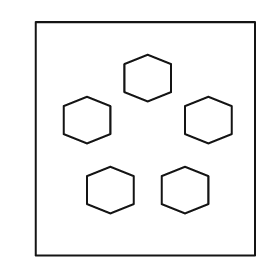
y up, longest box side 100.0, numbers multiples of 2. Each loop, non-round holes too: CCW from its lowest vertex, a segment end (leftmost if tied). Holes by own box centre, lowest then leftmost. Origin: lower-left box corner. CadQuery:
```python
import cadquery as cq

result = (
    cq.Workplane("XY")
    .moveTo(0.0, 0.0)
    .lineTo(94.0, 0.0)
    .lineTo(94.0, 100.0)
    .lineTo(0.0, 100.0)
    .close()
    .moveTo(32.0, 18.0)
    .lineTo(42.0, 22.0)
    .lineTo(42.0, 34.0)
    .lineTo(32.0, 38.0)
    .lineTo(22.0, 34.0)
    .lineTo(22.0, 22.0)
    .close()
    .moveTo(64.0, 18.0)
    .lineTo(74.0, 22.0)
    .lineTo(74.0, 34.0)
    .lineTo(64.0, 38.0)
    .lineTo(54.0, 34.0)
    .lineTo(54.0, 22.0)
    .close()
    .moveTo(22.0, 48.0)
    .lineTo(32.0, 52.0)
    .lineTo(32.0, 64.0)
    .lineTo(22.0, 68.0)
    .lineTo(12.0, 64.0)
    .lineTo(12.0, 52.0)
    .close()
    .moveTo(74.0, 48.0)
    .lineTo(84.0, 52.0)
    .lineTo(84.0, 64.0)
    .lineTo(74.0, 68.0)
    .lineTo(64.0, 64.0)
    .lineTo(64.0, 52.0)
    .close()
    .moveTo(48.0, 66.0)
    .lineTo(58.0, 70.0)
    .lineTo(58.0, 82.0)
    .lineTo(48.0, 86.0)
    .lineTo(38.0, 82.0)
    .lineTo(38.0, 70.0)
    .close()
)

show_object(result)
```